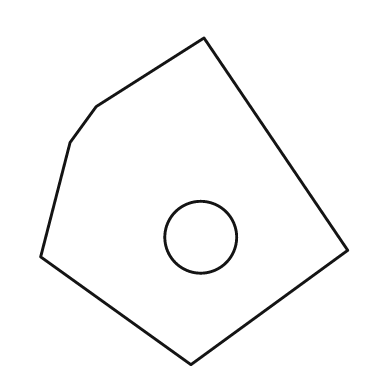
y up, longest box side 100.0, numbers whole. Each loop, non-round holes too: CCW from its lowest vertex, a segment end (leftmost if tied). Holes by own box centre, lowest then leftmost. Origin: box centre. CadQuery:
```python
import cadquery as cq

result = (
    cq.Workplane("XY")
    .moveTo(-1.0, -50.0)
    .lineTo(47.0, -15.0)
    .lineTo(3.0, 50.0)
    .lineTo(-30.0, 29.0)
    .lineTo(-38.0, 18.0)
    .lineTo(-47.0, -17.0)
    .close()
    .moveTo(2.0, -11.0)
    .circle(11.0)
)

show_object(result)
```